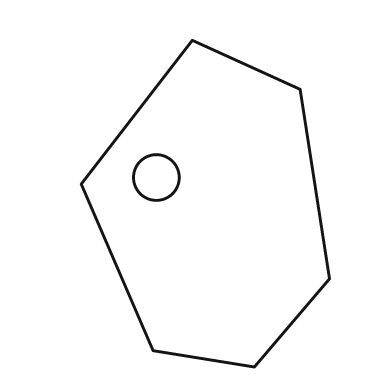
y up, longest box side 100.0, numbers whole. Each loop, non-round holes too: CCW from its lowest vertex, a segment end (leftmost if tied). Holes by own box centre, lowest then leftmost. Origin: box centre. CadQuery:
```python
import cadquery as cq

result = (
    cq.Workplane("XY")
    .moveTo(15.0, -50.0)
    .lineTo(38.0, -23.0)
    .lineTo(29.0, 35.0)
    .lineTo(-4.0, 50.0)
    .lineTo(-38.0, 6.0)
    .lineTo(-16.0, -45.0)
    .close()
    .moveTo(-15.0, 8.0)
    .circle(7.0)
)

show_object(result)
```